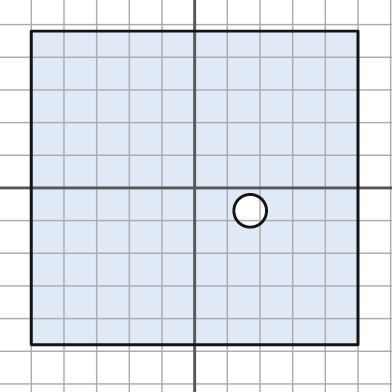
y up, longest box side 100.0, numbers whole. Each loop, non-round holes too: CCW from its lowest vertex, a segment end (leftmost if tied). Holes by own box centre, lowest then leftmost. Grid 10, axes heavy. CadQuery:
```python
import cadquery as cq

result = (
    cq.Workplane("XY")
    .moveTo(-50.0, -48.0)
    .lineTo(50.0, -48.0)
    .lineTo(50.0, 48.0)
    .lineTo(-50.0, 48.0)
    .close()
    .moveTo(17.0, -7.0)
    .circle(5.0)
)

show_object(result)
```